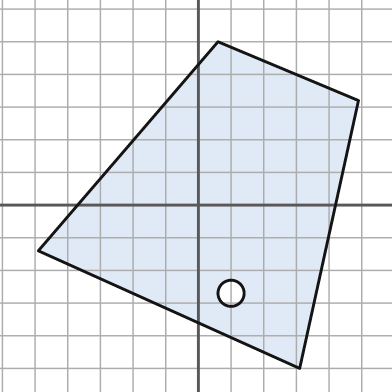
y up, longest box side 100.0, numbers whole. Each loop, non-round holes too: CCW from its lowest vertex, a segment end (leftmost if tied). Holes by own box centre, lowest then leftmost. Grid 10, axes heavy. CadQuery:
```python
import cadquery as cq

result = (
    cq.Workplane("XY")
    .moveTo(31.0, -50.0)
    .lineTo(49.0, 32.0)
    .lineTo(6.0, 50.0)
    .lineTo(-49.0, -14.0)
    .close()
    .moveTo(10.0, -27.0)
    .circle(4.0)
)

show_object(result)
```